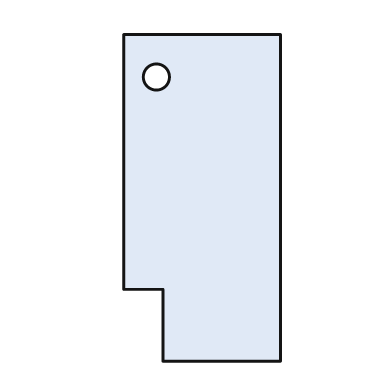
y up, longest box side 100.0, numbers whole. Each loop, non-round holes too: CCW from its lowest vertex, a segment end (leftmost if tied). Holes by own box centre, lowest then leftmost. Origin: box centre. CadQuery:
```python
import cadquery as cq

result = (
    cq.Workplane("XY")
    .moveTo(-12.0, -50.0)
    .lineTo(24.0, -50.0)
    .lineTo(24.0, 50.0)
    .lineTo(-24.0, 50.0)
    .lineTo(-24.0, -28.0)
    .lineTo(-12.0, -28.0)
    .close()
    .moveTo(-14.0, 37.0)
    .circle(4.0)
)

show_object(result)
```